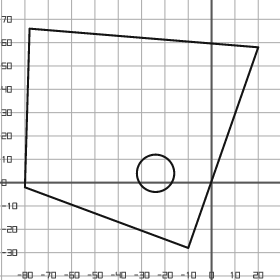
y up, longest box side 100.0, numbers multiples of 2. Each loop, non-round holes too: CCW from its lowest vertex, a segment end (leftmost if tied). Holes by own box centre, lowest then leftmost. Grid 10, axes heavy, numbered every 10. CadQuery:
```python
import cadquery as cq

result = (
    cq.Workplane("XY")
    .moveTo(-10.0, -28.0)
    .lineTo(20.0, 58.0)
    .lineTo(-78.0, 66.0)
    .lineTo(-80.0, -2.0)
    .close()
    .moveTo(-24.0, 4.0)
    .circle(8.0)
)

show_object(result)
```